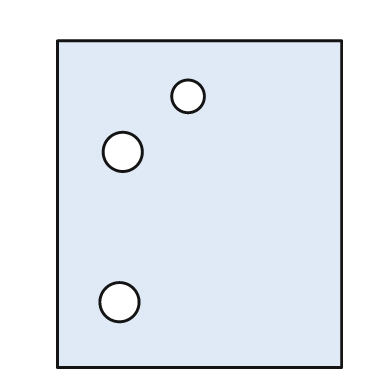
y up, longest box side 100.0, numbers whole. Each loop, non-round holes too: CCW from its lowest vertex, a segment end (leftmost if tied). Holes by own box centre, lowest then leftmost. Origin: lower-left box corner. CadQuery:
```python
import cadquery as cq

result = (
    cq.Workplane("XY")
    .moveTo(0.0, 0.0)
    .lineTo(87.0, 0.0)
    .lineTo(87.0, 100.0)
    .lineTo(0.0, 100.0)
    .close()
    .moveTo(19.0, 20.0)
    .circle(6.0)
    .moveTo(20.0, 66.0)
    .circle(6.0)
    .moveTo(40.0, 83.0)
    .circle(5.0)
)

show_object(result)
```